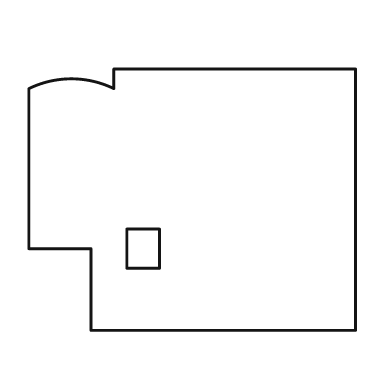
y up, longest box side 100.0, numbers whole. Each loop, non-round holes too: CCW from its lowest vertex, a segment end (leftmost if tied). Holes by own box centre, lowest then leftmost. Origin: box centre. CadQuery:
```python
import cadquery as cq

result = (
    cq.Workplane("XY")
    .moveTo(-31.0, -40.0)
    .lineTo(50.0, -40.0)
    .lineTo(50.0, 40.0)
    .lineTo(-24.0, 40.0)
    .lineTo(-24.0, 34.0)
    .threePointArc((-37.0, 37.0), (-50.0, 34.0))
    .lineTo(-50.0, -15.0)
    .lineTo(-31.0, -15.0)
    .close()
    .moveTo(-20.0, -21.0)
    .lineTo(-10.0, -21.0)
    .lineTo(-10.0, -9.0)
    .lineTo(-20.0, -9.0)
    .close()
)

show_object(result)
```